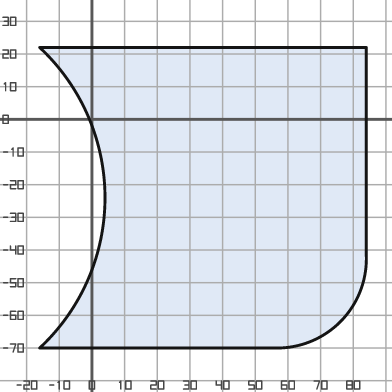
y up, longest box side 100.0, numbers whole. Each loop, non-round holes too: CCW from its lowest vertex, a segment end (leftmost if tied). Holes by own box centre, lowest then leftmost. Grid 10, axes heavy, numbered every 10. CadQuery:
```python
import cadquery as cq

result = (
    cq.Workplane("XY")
    .moveTo(-16.0, -70.0)
    .lineTo(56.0, -70.0)
    .threePointArc((76.0, -62.0), (84.0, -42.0))
    .lineTo(84.0, 22.0)
    .lineTo(-16.0, 22.0)
    .threePointArc((4.0, -24.0), (-16.0, -70.0))
    .close()
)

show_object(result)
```